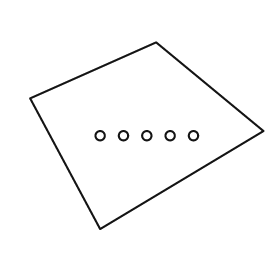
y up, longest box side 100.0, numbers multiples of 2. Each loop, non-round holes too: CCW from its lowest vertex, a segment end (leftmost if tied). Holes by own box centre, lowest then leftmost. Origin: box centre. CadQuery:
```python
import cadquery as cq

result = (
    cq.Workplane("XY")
    .moveTo(-20.0, -40.0)
    .lineTo(50.0, 2.0)
    .lineTo(4.0, 40.0)
    .lineTo(-50.0, 16.0)
    .close()
    .moveTo(-20.0, 0.0)
    .circle(2.0)
    .moveTo(-10.0, 0.0)
    .circle(2.0)
    .moveTo(0.0, 0.0)
    .circle(2.0)
    .moveTo(10.0, 0.0)
    .circle(2.0)
    .moveTo(20.0, 0.0)
    .circle(2.0)
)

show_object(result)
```